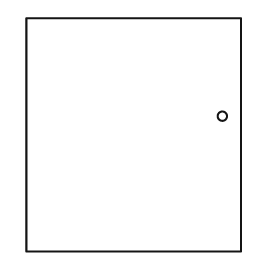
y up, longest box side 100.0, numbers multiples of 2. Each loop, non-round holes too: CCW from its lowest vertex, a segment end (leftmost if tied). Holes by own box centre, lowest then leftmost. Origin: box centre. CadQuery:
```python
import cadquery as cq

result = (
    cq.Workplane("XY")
    .moveTo(-46.0, -50.0)
    .lineTo(46.0, -50.0)
    .lineTo(46.0, 50.0)
    .lineTo(-46.0, 50.0)
    .close()
    .moveTo(38.0, 8.0)
    .circle(2.0)
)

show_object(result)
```